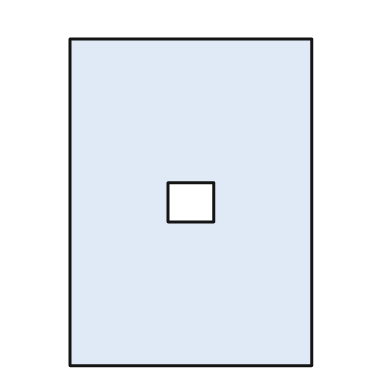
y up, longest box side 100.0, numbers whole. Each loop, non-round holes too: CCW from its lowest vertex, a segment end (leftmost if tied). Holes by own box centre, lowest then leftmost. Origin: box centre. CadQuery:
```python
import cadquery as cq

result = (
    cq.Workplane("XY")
    .moveTo(-37.0, -50.0)
    .lineTo(37.0, -50.0)
    .lineTo(37.0, 50.0)
    .lineTo(-37.0, 50.0)
    .close()
    .moveTo(-7.0, -6.0)
    .lineTo(7.0, -6.0)
    .lineTo(7.0, 6.0)
    .lineTo(-7.0, 6.0)
    .close()
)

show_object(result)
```